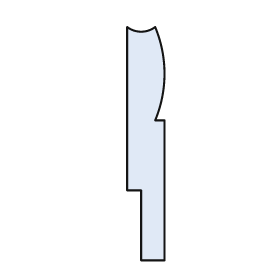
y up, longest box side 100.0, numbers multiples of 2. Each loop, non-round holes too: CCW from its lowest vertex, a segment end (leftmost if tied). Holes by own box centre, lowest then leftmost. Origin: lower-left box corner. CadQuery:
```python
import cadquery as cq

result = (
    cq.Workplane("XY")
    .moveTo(6.0, 0.0)
    .lineTo(16.0, 0.0)
    .lineTo(16.0, 60.0)
    .lineTo(12.0, 60.0)
    .threePointArc((16.0, 80.0), (12.0, 100.0))
    .threePointArc((6.0, 98.0), (0.0, 100.0))
    .lineTo(0.0, 30.0)
    .lineTo(6.0, 30.0)
    .close()
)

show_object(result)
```